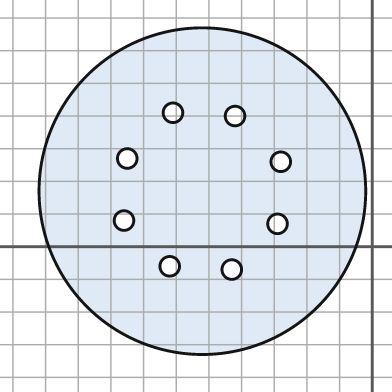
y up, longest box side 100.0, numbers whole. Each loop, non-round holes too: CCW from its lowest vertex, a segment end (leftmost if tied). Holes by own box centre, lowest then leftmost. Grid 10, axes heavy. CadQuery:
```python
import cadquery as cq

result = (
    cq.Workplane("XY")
    .moveTo(-52.0, 17.0)
    .circle(50.0)
    .moveTo(-43.0, -7.0)
    .circle(3.0)
    .moveTo(-62.0, -6.0)
    .circle(3.0)
    .moveTo(-29.0, 7.0)
    .circle(3.0)
    .moveTo(-76.0, 8.0)
    .circle(3.0)
    .moveTo(-28.0, 26.0)
    .circle(3.0)
    .moveTo(-75.0, 27.0)
    .circle(3.0)
    .moveTo(-42.0, 40.0)
    .circle(3.0)
    .moveTo(-61.0, 41.0)
    .circle(3.0)
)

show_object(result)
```